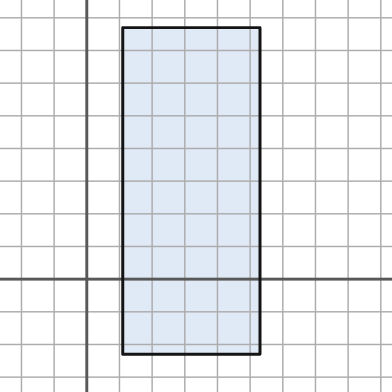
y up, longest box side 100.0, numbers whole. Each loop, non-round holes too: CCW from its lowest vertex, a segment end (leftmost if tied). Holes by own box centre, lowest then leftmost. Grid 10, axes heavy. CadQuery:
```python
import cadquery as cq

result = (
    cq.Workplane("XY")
    .moveTo(11.0, -23.0)
    .lineTo(53.0, -23.0)
    .lineTo(53.0, 77.0)
    .lineTo(11.0, 77.0)
    .close()
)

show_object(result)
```